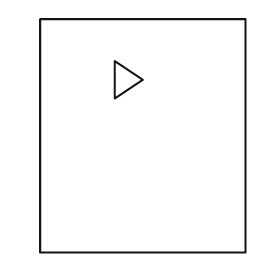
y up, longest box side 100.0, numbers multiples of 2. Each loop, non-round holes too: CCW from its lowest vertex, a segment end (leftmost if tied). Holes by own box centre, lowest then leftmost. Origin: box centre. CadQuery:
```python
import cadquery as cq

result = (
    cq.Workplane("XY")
    .moveTo(-44.0, -50.0)
    .lineTo(44.0, -50.0)
    .lineTo(44.0, 50.0)
    .lineTo(-44.0, 50.0)
    .close()
    .moveTo(-12.0, 16.0)
    .lineTo(0.0, 24.0)
    .lineTo(-12.0, 32.0)
    .close()
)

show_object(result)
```